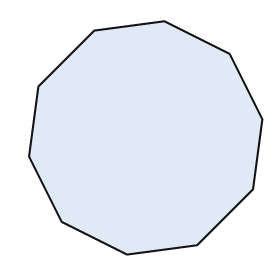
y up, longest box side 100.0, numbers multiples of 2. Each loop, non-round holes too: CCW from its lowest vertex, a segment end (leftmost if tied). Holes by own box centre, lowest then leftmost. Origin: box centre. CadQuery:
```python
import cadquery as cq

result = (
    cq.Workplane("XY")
    .moveTo(-8.0, -50.0)
    .lineTo(22.0, -46.0)
    .lineTo(46.0, -22.0)
    .lineTo(50.0, 8.0)
    .lineTo(36.0, 36.0)
    .lineTo(8.0, 50.0)
    .lineTo(-22.0, 46.0)
    .lineTo(-46.0, 22.0)
    .lineTo(-50.0, -8.0)
    .lineTo(-36.0, -36.0)
    .close()
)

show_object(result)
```